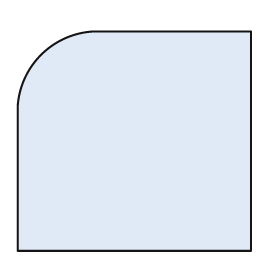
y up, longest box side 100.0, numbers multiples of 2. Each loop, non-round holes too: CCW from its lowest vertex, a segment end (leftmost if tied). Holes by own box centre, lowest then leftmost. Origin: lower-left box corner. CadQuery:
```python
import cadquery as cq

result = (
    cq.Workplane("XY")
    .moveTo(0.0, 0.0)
    .lineTo(100.0, 0.0)
    .lineTo(100.0, 94.0)
    .lineTo(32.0, 94.0)
    .threePointArc((10.0, 84.0), (0.0, 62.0))
    .close()
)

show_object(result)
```